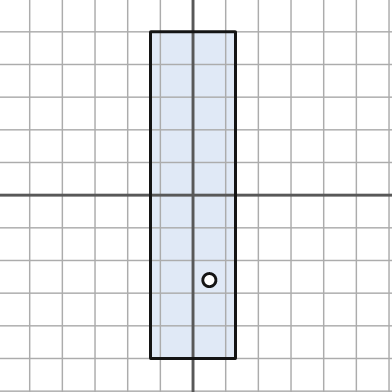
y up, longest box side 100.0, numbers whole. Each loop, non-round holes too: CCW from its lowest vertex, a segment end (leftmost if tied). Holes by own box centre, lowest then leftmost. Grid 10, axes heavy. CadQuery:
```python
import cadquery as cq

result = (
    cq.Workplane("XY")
    .moveTo(-13.0, -50.0)
    .lineTo(13.0, -50.0)
    .lineTo(13.0, 50.0)
    .lineTo(-13.0, 50.0)
    .close()
    .moveTo(5.0, -26.0)
    .circle(2.0)
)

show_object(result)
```